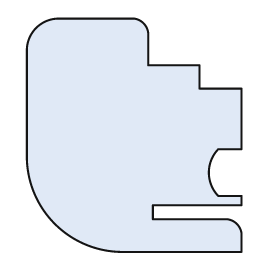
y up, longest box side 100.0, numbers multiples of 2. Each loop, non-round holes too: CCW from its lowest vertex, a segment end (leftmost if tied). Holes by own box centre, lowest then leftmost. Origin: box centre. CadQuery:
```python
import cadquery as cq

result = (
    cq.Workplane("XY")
    .moveTo(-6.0, -50.0)
    .lineTo(46.0, -50.0)
    .lineTo(46.0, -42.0)
    .threePointArc((44.0, -38.0), (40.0, -36.0))
    .lineTo(8.0, -36.0)
    .lineTo(8.0, -30.0)
    .lineTo(46.0, -30.0)
    .lineTo(46.0, -26.0)
    .lineTo(36.0, -26.0)
    .threePointArc((32.0, -16.0), (36.0, -6.0))
    .lineTo(46.0, -6.0)
    .lineTo(46.0, 20.0)
    .lineTo(28.0, 20.0)
    .lineTo(28.0, 30.0)
    .lineTo(6.0, 30.0)
    .lineTo(6.0, 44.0)
    .threePointArc((4.0, 48.0), (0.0, 50.0))
    .lineTo(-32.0, 50.0)
    .threePointArc((-42.0, 46.0), (-46.0, 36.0))
    .lineTo(-46.0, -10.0)
    .threePointArc((-34.0, -38.0), (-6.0, -50.0))
    .close()
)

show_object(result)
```